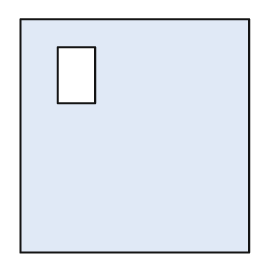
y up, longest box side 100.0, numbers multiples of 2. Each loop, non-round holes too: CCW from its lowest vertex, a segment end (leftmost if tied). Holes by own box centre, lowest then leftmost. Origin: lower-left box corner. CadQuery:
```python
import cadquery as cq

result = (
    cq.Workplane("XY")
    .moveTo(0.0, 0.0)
    .lineTo(98.0, 0.0)
    .lineTo(98.0, 100.0)
    .lineTo(0.0, 100.0)
    .close()
    .moveTo(16.0, 64.0)
    .lineTo(32.0, 64.0)
    .lineTo(32.0, 88.0)
    .lineTo(16.0, 88.0)
    .close()
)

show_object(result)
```